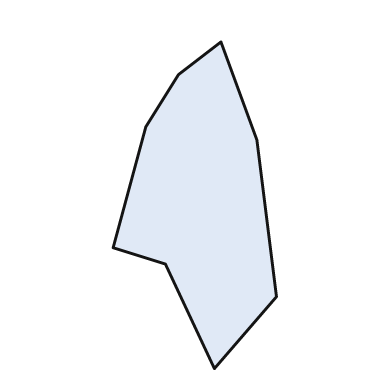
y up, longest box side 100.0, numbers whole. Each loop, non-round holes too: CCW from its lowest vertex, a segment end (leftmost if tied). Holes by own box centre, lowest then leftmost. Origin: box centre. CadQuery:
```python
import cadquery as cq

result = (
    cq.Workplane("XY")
    .moveTo(6.0, -50.0)
    .lineTo(25.0, -28.0)
    .lineTo(19.0, 20.0)
    .lineTo(8.0, 50.0)
    .lineTo(-5.0, 40.0)
    .lineTo(-15.0, 24.0)
    .lineTo(-25.0, -13.0)
    .lineTo(-9.0, -18.0)
    .close()
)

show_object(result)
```